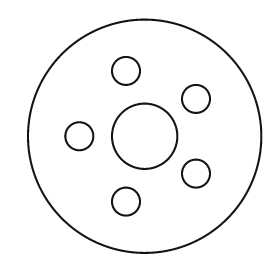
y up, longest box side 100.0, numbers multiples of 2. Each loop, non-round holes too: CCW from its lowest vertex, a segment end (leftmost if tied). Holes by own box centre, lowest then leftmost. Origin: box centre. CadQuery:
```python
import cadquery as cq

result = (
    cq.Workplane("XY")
    .moveTo(0.0, 0.0)
    .circle(50.0)
    .moveTo(-8.0, -28.0)
    .circle(6.0)
    .moveTo(22.0, -16.0)
    .circle(6.0)
    .moveTo(-28.0, 0.0)
    .circle(6.0)
    .moveTo(0.0, 0.0)
    .circle(14.0)
    .moveTo(22.0, 16.0)
    .circle(6.0)
    .moveTo(-8.0, 28.0)
    .circle(6.0)
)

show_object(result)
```